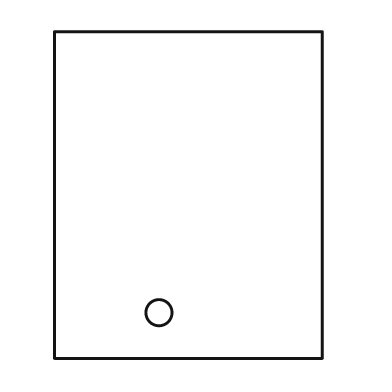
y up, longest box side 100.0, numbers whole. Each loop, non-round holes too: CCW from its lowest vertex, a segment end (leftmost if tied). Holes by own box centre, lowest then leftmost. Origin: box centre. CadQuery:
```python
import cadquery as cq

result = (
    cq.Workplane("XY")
    .moveTo(-41.0, -50.0)
    .lineTo(41.0, -50.0)
    .lineTo(41.0, 50.0)
    .lineTo(-41.0, 50.0)
    .close()
    .moveTo(-9.0, -36.0)
    .circle(4.0)
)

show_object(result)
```